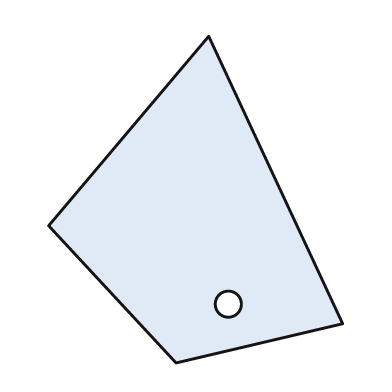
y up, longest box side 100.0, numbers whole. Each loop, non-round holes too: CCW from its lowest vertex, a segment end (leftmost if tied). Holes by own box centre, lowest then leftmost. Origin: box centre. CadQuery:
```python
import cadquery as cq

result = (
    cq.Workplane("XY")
    .moveTo(-6.0, -50.0)
    .lineTo(45.0, -38.0)
    .lineTo(4.0, 50.0)
    .lineTo(-45.0, -8.0)
    .close()
    .moveTo(10.0, -32.0)
    .circle(4.0)
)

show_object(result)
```